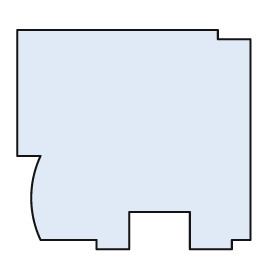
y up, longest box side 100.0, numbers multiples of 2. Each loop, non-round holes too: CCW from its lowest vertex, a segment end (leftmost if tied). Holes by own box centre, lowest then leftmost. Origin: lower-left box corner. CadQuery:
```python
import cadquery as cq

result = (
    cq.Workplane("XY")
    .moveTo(34.0, 0.0)
    .lineTo(48.0, 0.0)
    .lineTo(48.0, 16.0)
    .lineTo(74.0, 16.0)
    .lineTo(74.0, 0.0)
    .lineTo(92.0, 0.0)
    .lineTo(92.0, 4.0)
    .lineTo(100.0, 4.0)
    .lineTo(100.0, 90.0)
    .lineTo(86.0, 90.0)
    .lineTo(86.0, 94.0)
    .lineTo(0.0, 94.0)
    .lineTo(0.0, 40.0)
    .lineTo(10.0, 40.0)
    .threePointArc((6.0, 22.0), (10.0, 4.0))
    .lineTo(34.0, 4.0)
    .close()
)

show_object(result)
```